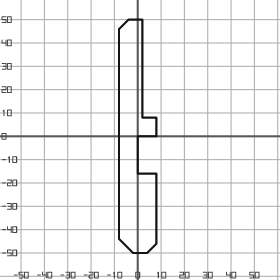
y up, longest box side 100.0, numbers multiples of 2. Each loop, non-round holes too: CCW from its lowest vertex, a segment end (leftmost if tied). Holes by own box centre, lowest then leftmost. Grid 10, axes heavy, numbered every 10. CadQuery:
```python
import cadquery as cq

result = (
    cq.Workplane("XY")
    .moveTo(-2.0, -50.0)
    .lineTo(4.0, -50.0)
    .lineTo(8.0, -46.0)
    .lineTo(8.0, -16.0)
    .lineTo(0.0, -16.0)
    .lineTo(0.0, 0.0)
    .lineTo(8.0, 0.0)
    .lineTo(8.0, 8.0)
    .lineTo(2.0, 8.0)
    .lineTo(2.0, 50.0)
    .lineTo(-4.0, 50.0)
    .lineTo(-8.0, 46.0)
    .lineTo(-8.0, -44.0)
    .close()
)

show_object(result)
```